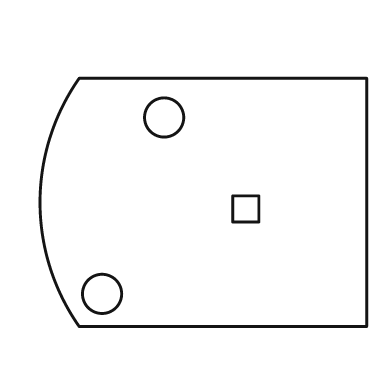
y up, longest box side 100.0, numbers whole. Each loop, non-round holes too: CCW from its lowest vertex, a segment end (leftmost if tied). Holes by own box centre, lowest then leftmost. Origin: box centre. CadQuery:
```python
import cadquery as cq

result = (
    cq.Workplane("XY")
    .moveTo(-38.0, -38.0)
    .lineTo(50.0, -38.0)
    .lineTo(50.0, 38.0)
    .lineTo(-38.0, 38.0)
    .threePointArc((-50.0, 0.0), (-38.0, -38.0))
    .close()
    .moveTo(-31.0, -28.0)
    .circle(6.0)
    .moveTo(9.0, -6.0)
    .lineTo(17.0, -6.0)
    .lineTo(17.0, 2.0)
    .lineTo(9.0, 2.0)
    .close()
    .moveTo(-12.0, 26.0)
    .circle(6.0)
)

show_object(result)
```